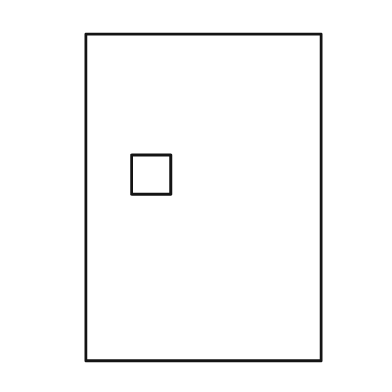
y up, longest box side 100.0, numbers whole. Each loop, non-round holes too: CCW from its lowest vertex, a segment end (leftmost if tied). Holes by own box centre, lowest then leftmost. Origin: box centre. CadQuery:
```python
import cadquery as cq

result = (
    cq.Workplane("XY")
    .moveTo(-36.0, -50.0)
    .lineTo(36.0, -50.0)
    .lineTo(36.0, 50.0)
    .lineTo(-36.0, 50.0)
    .close()
    .moveTo(-22.0, 1.0)
    .lineTo(-10.0, 1.0)
    .lineTo(-10.0, 13.0)
    .lineTo(-22.0, 13.0)
    .close()
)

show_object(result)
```